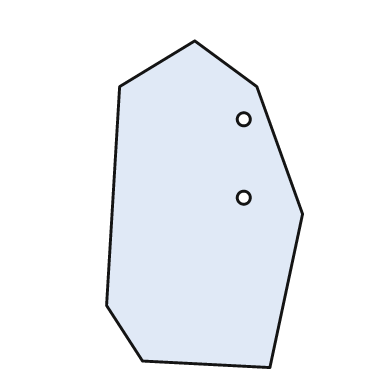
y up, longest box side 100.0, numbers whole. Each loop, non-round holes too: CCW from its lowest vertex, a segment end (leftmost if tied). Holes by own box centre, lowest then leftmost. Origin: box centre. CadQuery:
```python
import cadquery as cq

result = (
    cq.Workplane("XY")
    .moveTo(20.0, -50.0)
    .lineTo(30.0, -3.0)
    .lineTo(16.0, 36.0)
    .lineTo(-3.0, 50.0)
    .lineTo(-26.0, 36.0)
    .lineTo(-30.0, -31.0)
    .lineTo(-19.0, -48.0)
    .close()
    .moveTo(12.0, 2.0)
    .circle(2.0)
    .moveTo(12.0, 26.0)
    .circle(2.0)
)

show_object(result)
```